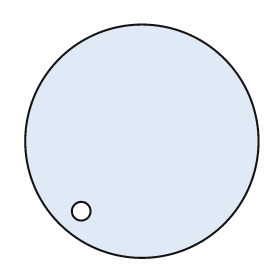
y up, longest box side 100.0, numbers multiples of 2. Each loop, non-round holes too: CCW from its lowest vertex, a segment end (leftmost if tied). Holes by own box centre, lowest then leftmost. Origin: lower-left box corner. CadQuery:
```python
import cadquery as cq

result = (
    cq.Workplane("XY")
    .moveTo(50.0, 50.0)
    .circle(50.0)
    .moveTo(24.0, 20.0)
    .circle(4.0)
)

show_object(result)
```